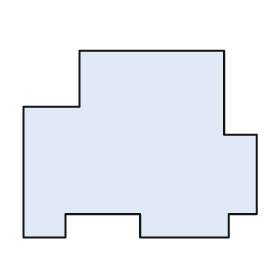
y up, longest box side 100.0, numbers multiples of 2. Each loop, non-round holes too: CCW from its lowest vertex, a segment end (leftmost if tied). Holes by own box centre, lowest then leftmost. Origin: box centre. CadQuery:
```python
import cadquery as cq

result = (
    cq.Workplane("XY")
    .moveTo(-50.0, -40.0)
    .lineTo(-32.0, -40.0)
    .lineTo(-32.0, -30.0)
    .lineTo(0.0, -30.0)
    .lineTo(0.0, -40.0)
    .lineTo(38.0, -40.0)
    .lineTo(38.0, -30.0)
    .lineTo(50.0, -30.0)
    .lineTo(50.0, 4.0)
    .lineTo(36.0, 4.0)
    .lineTo(36.0, 40.0)
    .lineTo(-26.0, 40.0)
    .lineTo(-26.0, 16.0)
    .lineTo(-50.0, 16.0)
    .close()
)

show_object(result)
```